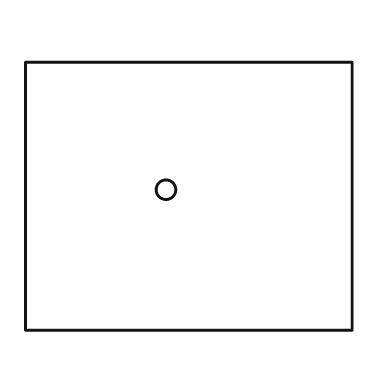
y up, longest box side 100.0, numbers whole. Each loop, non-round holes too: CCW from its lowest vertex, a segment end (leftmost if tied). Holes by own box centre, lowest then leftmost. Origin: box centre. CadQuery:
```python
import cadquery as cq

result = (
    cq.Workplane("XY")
    .moveTo(-50.0, -41.0)
    .lineTo(50.0, -41.0)
    .lineTo(50.0, 41.0)
    .lineTo(-50.0, 41.0)
    .close()
    .moveTo(-7.0, 2.0)
    .circle(3.0)
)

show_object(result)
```